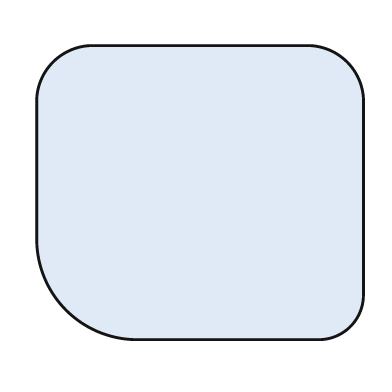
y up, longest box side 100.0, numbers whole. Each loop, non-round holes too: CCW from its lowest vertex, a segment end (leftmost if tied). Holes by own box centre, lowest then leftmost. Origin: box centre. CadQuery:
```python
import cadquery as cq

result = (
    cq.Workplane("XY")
    .moveTo(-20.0, -45.0)
    .lineTo(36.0, -45.0)
    .threePointArc((46.0, -41.0), (50.0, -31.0))
    .lineTo(50.0, 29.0)
    .threePointArc((45.0, 40.0), (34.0, 45.0))
    .lineTo(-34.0, 45.0)
    .threePointArc((-45.0, 40.0), (-50.0, 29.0))
    .lineTo(-50.0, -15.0)
    .threePointArc((-41.0, -36.0), (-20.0, -45.0))
    .close()
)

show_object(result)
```